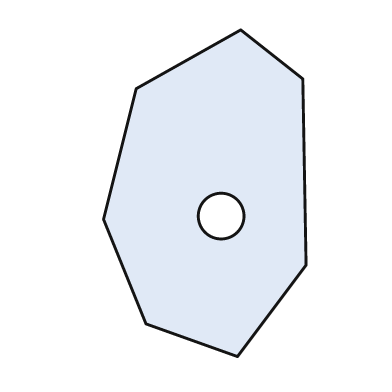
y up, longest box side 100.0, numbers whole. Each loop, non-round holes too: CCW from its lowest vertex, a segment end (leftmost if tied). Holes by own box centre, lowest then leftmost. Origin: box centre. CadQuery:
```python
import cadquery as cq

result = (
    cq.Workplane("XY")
    .moveTo(10.0, -50.0)
    .lineTo(31.0, -22.0)
    .lineTo(30.0, 35.0)
    .lineTo(11.0, 50.0)
    .lineTo(-21.0, 32.0)
    .lineTo(-31.0, -8.0)
    .lineTo(-18.0, -40.0)
    .close()
    .moveTo(5.0, -7.0)
    .circle(7.0)
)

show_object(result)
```